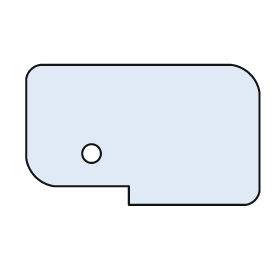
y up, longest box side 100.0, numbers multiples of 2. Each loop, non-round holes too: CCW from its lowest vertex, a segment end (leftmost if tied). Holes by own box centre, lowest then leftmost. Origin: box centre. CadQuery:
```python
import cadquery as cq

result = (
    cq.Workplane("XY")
    .moveTo(-6.0, -30.0)
    .lineTo(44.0, -30.0)
    .threePointArc((48.0, -28.0), (50.0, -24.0))
    .lineTo(50.0, 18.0)
    .threePointArc((46.0, 26.0), (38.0, 30.0))
    .lineTo(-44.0, 30.0)
    .threePointArc((-48.0, 28.0), (-50.0, 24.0))
    .lineTo(-50.0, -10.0)
    .threePointArc((-46.0, -18.0), (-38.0, -22.0))
    .lineTo(-6.0, -22.0)
    .close()
    .moveTo(-22.0, -8.0)
    .circle(4.0)
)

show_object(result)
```